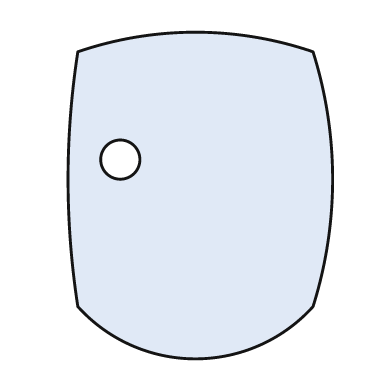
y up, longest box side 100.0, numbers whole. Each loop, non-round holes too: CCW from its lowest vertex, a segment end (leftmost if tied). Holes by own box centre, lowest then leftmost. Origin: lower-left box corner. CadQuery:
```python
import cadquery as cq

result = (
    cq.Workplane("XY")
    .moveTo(3.0, 16.0)
    .threePointArc((39.0, 0.0), (75.0, 16.0))
    .threePointArc((81.0, 55.0), (75.0, 94.0))
    .threePointArc((39.0, 100.0), (3.0, 94.0))
    .threePointArc((0.0, 55.0), (3.0, 16.0))
    .close()
    .moveTo(16.0, 61.0)
    .circle(6.0)
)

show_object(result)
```